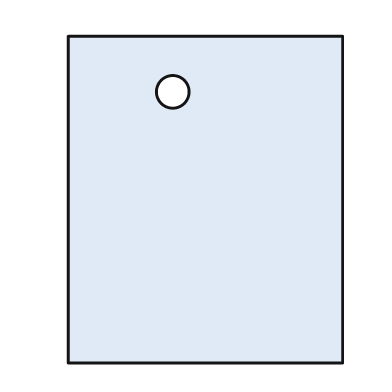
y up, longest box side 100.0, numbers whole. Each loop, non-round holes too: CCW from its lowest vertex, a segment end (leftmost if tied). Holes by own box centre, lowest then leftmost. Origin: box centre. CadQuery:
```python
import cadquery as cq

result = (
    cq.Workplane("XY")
    .moveTo(-42.0, -50.0)
    .lineTo(42.0, -50.0)
    .lineTo(42.0, 50.0)
    .lineTo(-42.0, 50.0)
    .close()
    .moveTo(-10.0, 33.0)
    .circle(5.0)
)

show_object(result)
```